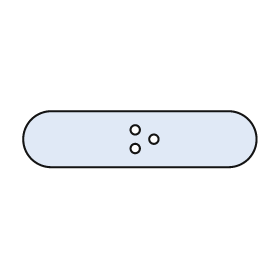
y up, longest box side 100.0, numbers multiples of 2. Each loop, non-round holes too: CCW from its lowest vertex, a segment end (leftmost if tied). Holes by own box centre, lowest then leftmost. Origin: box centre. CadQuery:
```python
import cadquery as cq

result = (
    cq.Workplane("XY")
    .moveTo(-38.0, -12.0)
    .lineTo(38.0, -12.0)
    .threePointArc((50.0, 0.0), (38.0, 12.0))
    .lineTo(-38.0, 12.0)
    .threePointArc((-50.0, 0.0), (-38.0, -12.0))
    .close()
    .moveTo(-2.0, -4.0)
    .circle(2.0)
    .moveTo(6.0, 0.0)
    .circle(2.0)
    .moveTo(-2.0, 4.0)
    .circle(2.0)
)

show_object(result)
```